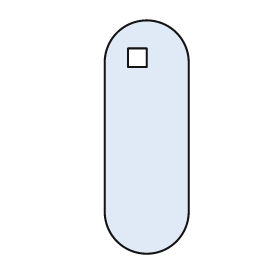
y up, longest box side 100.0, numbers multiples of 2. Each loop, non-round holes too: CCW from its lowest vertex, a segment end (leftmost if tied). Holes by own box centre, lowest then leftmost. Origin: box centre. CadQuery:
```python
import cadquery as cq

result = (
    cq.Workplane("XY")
    .moveTo(-18.0, -32.0)
    .threePointArc((0.0, -50.0), (18.0, -32.0))
    .lineTo(18.0, 32.0)
    .threePointArc((0.0, 50.0), (-18.0, 32.0))
    .close()
    .moveTo(-8.0, 30.0)
    .lineTo(0.0, 30.0)
    .lineTo(0.0, 38.0)
    .lineTo(-8.0, 38.0)
    .close()
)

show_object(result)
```